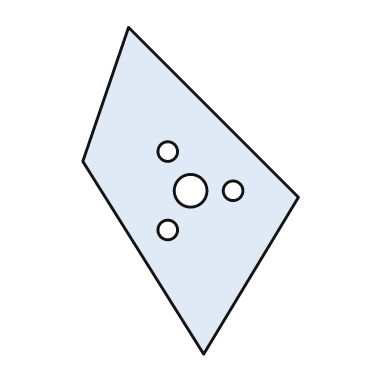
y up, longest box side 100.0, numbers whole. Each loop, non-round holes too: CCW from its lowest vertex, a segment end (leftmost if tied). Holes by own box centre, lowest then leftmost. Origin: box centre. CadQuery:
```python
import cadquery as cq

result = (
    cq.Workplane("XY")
    .moveTo(4.0, -50.0)
    .lineTo(33.0, -2.0)
    .lineTo(-19.0, 50.0)
    .lineTo(-33.0, 9.0)
    .close()
    .moveTo(-7.0, -12.0)
    .circle(3.0)
    .moveTo(0.0, 0.0)
    .circle(5.0)
    .moveTo(13.0, 0.0)
    .circle(3.0)
    .moveTo(-7.0, 12.0)
    .circle(3.0)
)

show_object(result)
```